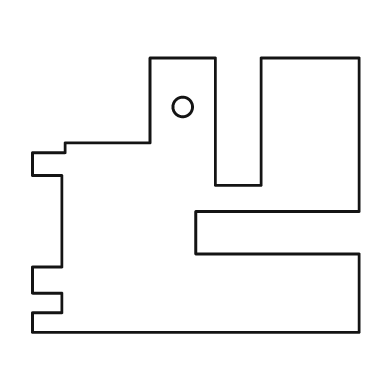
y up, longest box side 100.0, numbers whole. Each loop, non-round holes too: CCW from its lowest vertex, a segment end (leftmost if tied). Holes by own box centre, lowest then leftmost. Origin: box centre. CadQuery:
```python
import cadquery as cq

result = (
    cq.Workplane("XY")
    .moveTo(-50.0, -42.0)
    .lineTo(50.0, -42.0)
    .lineTo(50.0, -18.0)
    .lineTo(0.0, -18.0)
    .lineTo(0.0, -5.0)
    .lineTo(50.0, -5.0)
    .lineTo(50.0, 42.0)
    .lineTo(20.0, 42.0)
    .lineTo(20.0, 3.0)
    .lineTo(6.0, 3.0)
    .lineTo(6.0, 42.0)
    .lineTo(-14.0, 42.0)
    .lineTo(-14.0, 16.0)
    .lineTo(-40.0, 16.0)
    .lineTo(-40.0, 13.0)
    .lineTo(-50.0, 13.0)
    .lineTo(-50.0, 6.0)
    .lineTo(-41.0, 6.0)
    .lineTo(-41.0, -22.0)
    .lineTo(-50.0, -22.0)
    .lineTo(-50.0, -30.0)
    .lineTo(-41.0, -30.0)
    .lineTo(-41.0, -36.0)
    .lineTo(-50.0, -36.0)
    .close()
    .moveTo(-4.0, 27.0)
    .circle(3.0)
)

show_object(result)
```